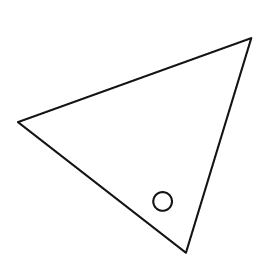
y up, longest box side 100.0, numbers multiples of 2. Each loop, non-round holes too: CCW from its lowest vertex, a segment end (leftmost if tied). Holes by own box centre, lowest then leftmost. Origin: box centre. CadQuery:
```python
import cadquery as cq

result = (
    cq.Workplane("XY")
    .moveTo(22.0, -46.0)
    .lineTo(50.0, 46.0)
    .lineTo(-50.0, 10.0)
    .close()
    .moveTo(12.0, -24.0)
    .circle(4.0)
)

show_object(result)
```